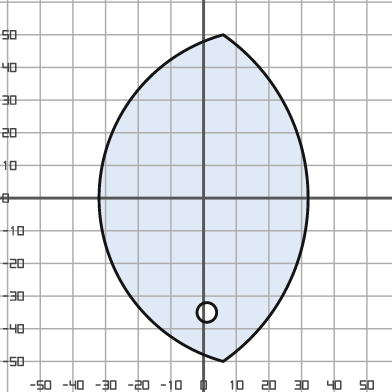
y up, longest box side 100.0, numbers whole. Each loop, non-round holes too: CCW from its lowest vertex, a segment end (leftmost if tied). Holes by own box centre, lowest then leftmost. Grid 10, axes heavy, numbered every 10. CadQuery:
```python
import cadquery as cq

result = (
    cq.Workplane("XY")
    .moveTo(6.0, -50.0)
    .threePointArc((32.0, 0.0), (6.0, 50.0))
    .threePointArc((-32.0, 0.0), (6.0, -50.0))
    .close()
    .moveTo(1.0, -35.0)
    .circle(3.0)
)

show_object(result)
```